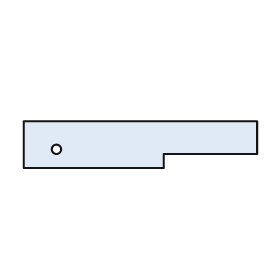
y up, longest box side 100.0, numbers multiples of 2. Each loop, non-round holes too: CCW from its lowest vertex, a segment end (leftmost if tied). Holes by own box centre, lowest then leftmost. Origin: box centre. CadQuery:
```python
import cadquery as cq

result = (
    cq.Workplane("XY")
    .moveTo(-50.0, -10.0)
    .lineTo(10.0, -10.0)
    .lineTo(10.0, -4.0)
    .lineTo(50.0, -4.0)
    .lineTo(50.0, 10.0)
    .lineTo(-50.0, 10.0)
    .close()
    .moveTo(-36.0, -2.0)
    .circle(2.0)
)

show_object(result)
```